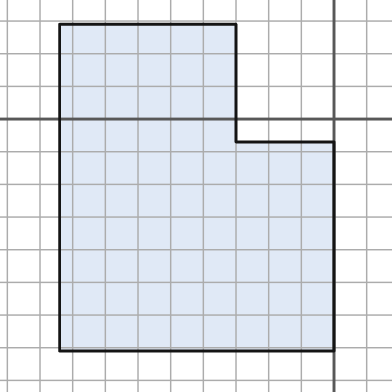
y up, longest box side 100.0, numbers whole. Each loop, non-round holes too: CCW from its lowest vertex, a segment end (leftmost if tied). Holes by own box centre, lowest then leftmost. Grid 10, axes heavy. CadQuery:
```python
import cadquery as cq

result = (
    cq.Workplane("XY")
    .moveTo(-84.0, -71.0)
    .lineTo(0.0, -71.0)
    .lineTo(0.0, -7.0)
    .lineTo(-30.0, -7.0)
    .lineTo(-30.0, 29.0)
    .lineTo(-84.0, 29.0)
    .close()
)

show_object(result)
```